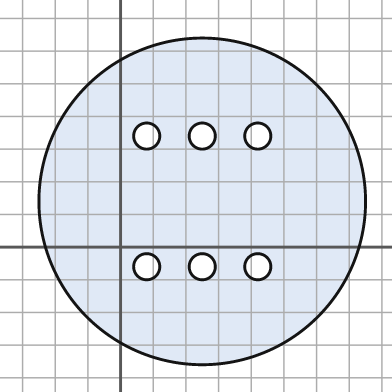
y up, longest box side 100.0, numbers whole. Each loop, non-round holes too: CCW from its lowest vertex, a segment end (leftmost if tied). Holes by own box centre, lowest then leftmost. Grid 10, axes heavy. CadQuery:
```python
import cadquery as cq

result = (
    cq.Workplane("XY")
    .moveTo(25.0, 14.0)
    .circle(50.0)
    .moveTo(8.0, -6.0)
    .circle(4.0)
    .moveTo(25.0, -6.0)
    .circle(4.0)
    .moveTo(42.0, -6.0)
    .circle(4.0)
    .moveTo(8.0, 34.0)
    .circle(4.0)
    .moveTo(25.0, 34.0)
    .circle(4.0)
    .moveTo(42.0, 34.0)
    .circle(4.0)
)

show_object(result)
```